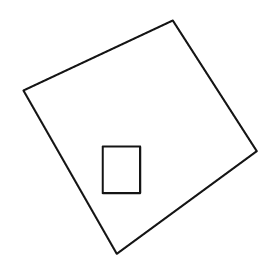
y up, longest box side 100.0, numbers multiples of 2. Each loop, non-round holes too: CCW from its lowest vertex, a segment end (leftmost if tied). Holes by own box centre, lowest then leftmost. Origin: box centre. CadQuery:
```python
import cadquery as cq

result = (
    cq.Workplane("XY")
    .moveTo(-10.0, -50.0)
    .lineTo(50.0, -6.0)
    .lineTo(14.0, 50.0)
    .lineTo(-50.0, 20.0)
    .close()
    .moveTo(-16.0, -24.0)
    .lineTo(0.0, -24.0)
    .lineTo(0.0, -4.0)
    .lineTo(-16.0, -4.0)
    .close()
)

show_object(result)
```